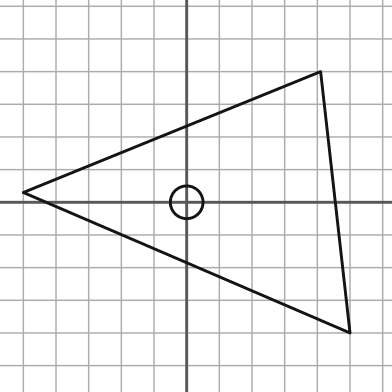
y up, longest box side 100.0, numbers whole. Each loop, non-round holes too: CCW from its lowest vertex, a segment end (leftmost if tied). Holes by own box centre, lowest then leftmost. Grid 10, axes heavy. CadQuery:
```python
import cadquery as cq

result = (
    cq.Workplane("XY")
    .moveTo(50.0, -40.0)
    .lineTo(41.0, 40.0)
    .lineTo(-50.0, 3.0)
    .close()
    .moveTo(0.0, 0.0)
    .circle(5.0)
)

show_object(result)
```